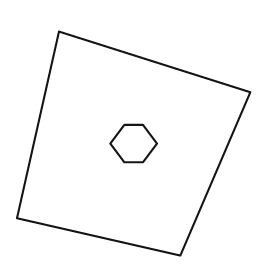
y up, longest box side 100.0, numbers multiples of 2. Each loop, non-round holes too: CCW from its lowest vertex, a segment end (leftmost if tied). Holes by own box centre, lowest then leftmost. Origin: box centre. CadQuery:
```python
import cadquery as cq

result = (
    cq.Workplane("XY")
    .moveTo(20.0, -48.0)
    .lineTo(50.0, 22.0)
    .lineTo(-32.0, 48.0)
    .lineTo(-50.0, -32.0)
    .close()
    .moveTo(-4.0, -8.0)
    .lineTo(4.0, -8.0)
    .lineTo(10.0, 0.0)
    .lineTo(4.0, 8.0)
    .lineTo(-4.0, 8.0)
    .lineTo(-10.0, 0.0)
    .close()
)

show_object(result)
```